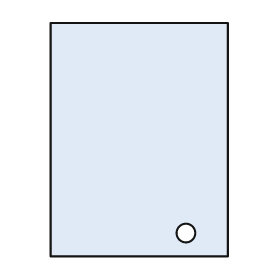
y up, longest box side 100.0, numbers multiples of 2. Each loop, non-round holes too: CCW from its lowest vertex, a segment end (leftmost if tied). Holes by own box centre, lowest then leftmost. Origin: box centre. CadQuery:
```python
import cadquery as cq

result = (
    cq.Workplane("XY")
    .moveTo(-38.0, -50.0)
    .lineTo(38.0, -50.0)
    .lineTo(38.0, 50.0)
    .lineTo(-38.0, 50.0)
    .close()
    .moveTo(20.0, -40.0)
    .circle(4.0)
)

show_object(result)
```